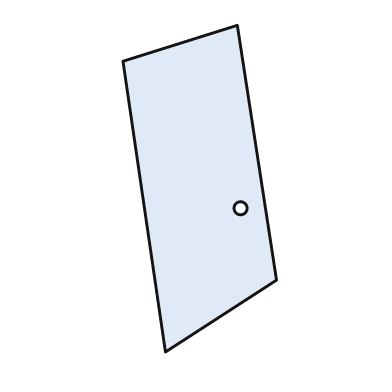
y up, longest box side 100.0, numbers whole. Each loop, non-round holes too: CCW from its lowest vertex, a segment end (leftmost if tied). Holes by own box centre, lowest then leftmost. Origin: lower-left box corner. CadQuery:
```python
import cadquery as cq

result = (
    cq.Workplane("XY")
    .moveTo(13.0, 0.0)
    .lineTo(47.0, 22.0)
    .lineTo(35.0, 100.0)
    .lineTo(0.0, 89.0)
    .close()
    .moveTo(36.0, 44.0)
    .circle(2.0)
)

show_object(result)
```